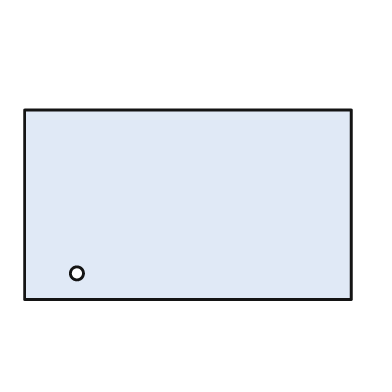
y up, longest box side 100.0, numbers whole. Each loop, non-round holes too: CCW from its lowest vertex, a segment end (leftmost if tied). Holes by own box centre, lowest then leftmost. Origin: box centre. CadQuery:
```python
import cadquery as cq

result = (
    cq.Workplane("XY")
    .moveTo(-50.0, -29.0)
    .lineTo(50.0, -29.0)
    .lineTo(50.0, 29.0)
    .lineTo(-50.0, 29.0)
    .close()
    .moveTo(-34.0, -21.0)
    .circle(2.0)
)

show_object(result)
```